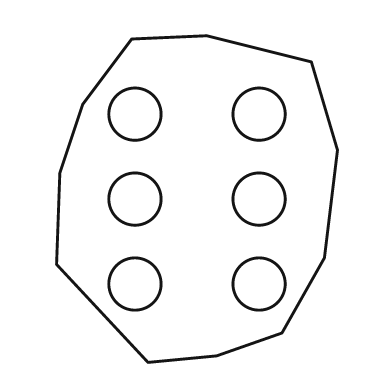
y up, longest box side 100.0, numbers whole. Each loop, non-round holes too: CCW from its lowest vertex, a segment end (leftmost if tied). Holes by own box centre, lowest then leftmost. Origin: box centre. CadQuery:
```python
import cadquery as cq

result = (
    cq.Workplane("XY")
    .moveTo(-15.0, -50.0)
    .lineTo(6.0, -48.0)
    .lineTo(26.0, -41.0)
    .lineTo(39.0, -18.0)
    .lineTo(43.0, 15.0)
    .lineTo(35.0, 42.0)
    .lineTo(3.0, 50.0)
    .lineTo(-20.0, 49.0)
    .lineTo(-35.0, 29.0)
    .lineTo(-42.0, 8.0)
    .lineTo(-43.0, -20.0)
    .close()
    .moveTo(-19.0, -26.0)
    .circle(8.0)
    .moveTo(19.0, -26.0)
    .circle(8.0)
    .moveTo(-19.0, 0.0)
    .circle(8.0)
    .moveTo(19.0, 0.0)
    .circle(8.0)
    .moveTo(-19.0, 26.0)
    .circle(8.0)
    .moveTo(19.0, 26.0)
    .circle(8.0)
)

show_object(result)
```